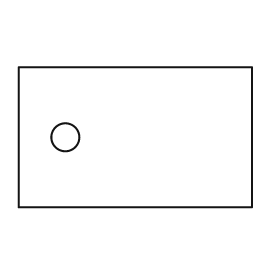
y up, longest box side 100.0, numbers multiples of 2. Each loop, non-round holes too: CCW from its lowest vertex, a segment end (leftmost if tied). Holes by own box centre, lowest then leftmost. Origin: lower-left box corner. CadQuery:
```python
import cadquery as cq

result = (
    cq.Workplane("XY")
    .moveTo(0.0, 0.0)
    .lineTo(100.0, 0.0)
    .lineTo(100.0, 60.0)
    .lineTo(0.0, 60.0)
    .close()
    .moveTo(20.0, 30.0)
    .circle(6.0)
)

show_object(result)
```